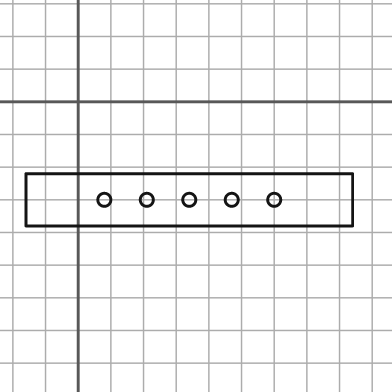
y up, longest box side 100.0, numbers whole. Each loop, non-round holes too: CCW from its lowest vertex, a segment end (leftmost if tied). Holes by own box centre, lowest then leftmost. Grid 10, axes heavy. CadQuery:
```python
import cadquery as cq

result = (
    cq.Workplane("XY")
    .moveTo(-16.0, -38.0)
    .lineTo(84.0, -38.0)
    .lineTo(84.0, -22.0)
    .lineTo(-16.0, -22.0)
    .close()
    .moveTo(8.0, -30.0)
    .circle(2.0)
    .moveTo(21.0, -30.0)
    .circle(2.0)
    .moveTo(34.0, -30.0)
    .circle(2.0)
    .moveTo(47.0, -30.0)
    .circle(2.0)
    .moveTo(60.0, -30.0)
    .circle(2.0)
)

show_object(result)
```